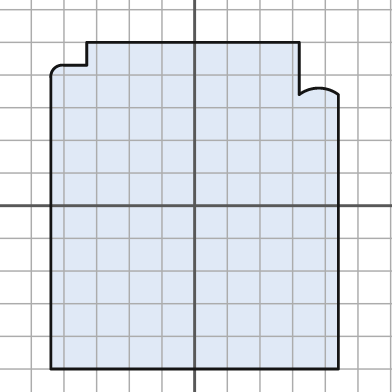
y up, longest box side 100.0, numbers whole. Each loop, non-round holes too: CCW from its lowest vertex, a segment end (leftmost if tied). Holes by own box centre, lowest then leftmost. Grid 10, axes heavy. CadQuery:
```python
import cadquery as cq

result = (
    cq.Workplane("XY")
    .moveTo(-44.0, -50.0)
    .lineTo(44.0, -50.0)
    .lineTo(44.0, 34.0)
    .threePointArc((38.0, 36.0), (32.0, 34.0))
    .lineTo(32.0, 50.0)
    .lineTo(-33.0, 50.0)
    .lineTo(-33.0, 43.0)
    .lineTo(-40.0, 43.0)
    .threePointArc((-43.0, 42.0), (-44.0, 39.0))
    .close()
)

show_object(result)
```